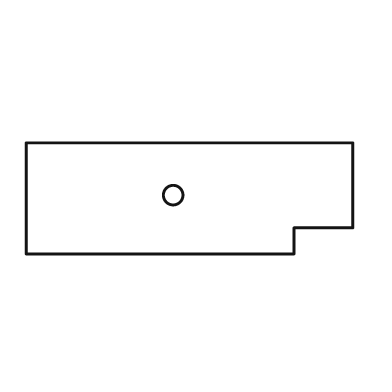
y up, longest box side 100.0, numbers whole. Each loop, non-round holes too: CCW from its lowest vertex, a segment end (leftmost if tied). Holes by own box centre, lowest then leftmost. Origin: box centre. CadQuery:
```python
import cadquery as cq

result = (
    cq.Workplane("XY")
    .moveTo(-50.0, -17.0)
    .lineTo(32.0, -17.0)
    .lineTo(32.0, -9.0)
    .lineTo(50.0, -9.0)
    .lineTo(50.0, 17.0)
    .lineTo(-50.0, 17.0)
    .close()
    .moveTo(-5.0, 1.0)
    .circle(3.0)
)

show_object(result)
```